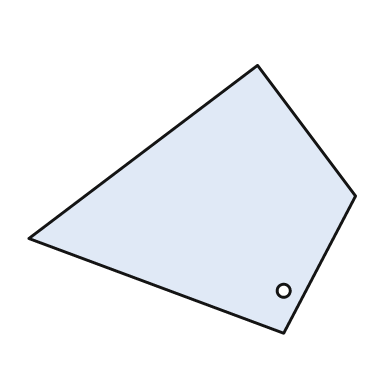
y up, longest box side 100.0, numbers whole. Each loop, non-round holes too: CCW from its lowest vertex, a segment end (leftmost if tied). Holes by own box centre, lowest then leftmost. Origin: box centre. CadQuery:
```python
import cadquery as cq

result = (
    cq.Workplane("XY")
    .moveTo(28.0, -41.0)
    .lineTo(50.0, 1.0)
    .lineTo(20.0, 41.0)
    .lineTo(-50.0, -12.0)
    .close()
    .moveTo(28.0, -28.0)
    .circle(2.0)
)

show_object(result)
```